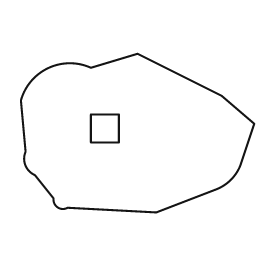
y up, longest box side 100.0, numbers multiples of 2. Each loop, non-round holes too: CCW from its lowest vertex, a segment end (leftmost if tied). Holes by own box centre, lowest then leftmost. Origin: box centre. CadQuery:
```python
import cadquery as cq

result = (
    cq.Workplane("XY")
    .moveTo(8.0, -34.0)
    .lineTo(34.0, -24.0)
    .threePointArc((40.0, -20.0), (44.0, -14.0))
    .lineTo(50.0, 4.0)
    .lineTo(36.0, 16.0)
    .lineTo(0.0, 34.0)
    .lineTo(-20.0, 28.0)
    .threePointArc((-38.0, 28.0), (-50.0, 14.0))
    .lineTo(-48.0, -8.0)
    .threePointArc((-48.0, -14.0), (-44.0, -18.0))
    .lineTo(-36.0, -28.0)
    .threePointArc((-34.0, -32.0), (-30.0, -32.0))
    .close()
    .moveTo(-20.0, -4.0)
    .lineTo(-8.0, -4.0)
    .lineTo(-8.0, 8.0)
    .lineTo(-20.0, 8.0)
    .close()
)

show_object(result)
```